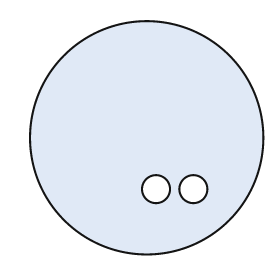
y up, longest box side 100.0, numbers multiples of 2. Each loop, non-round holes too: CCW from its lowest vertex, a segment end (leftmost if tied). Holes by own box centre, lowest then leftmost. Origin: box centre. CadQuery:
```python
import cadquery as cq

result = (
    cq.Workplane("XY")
    .moveTo(0.0, 0.0)
    .circle(50.0)
    .moveTo(4.0, -22.0)
    .circle(6.0)
    .moveTo(20.0, -22.0)
    .circle(6.0)
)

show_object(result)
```